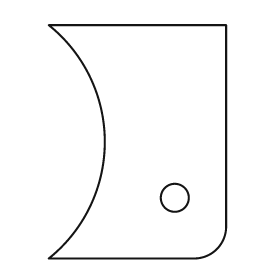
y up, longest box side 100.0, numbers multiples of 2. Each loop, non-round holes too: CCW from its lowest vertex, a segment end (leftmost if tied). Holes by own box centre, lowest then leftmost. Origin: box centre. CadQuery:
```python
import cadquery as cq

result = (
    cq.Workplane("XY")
    .moveTo(-38.0, -50.0)
    .lineTo(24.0, -50.0)
    .threePointArc((34.0, -46.0), (38.0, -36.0))
    .lineTo(38.0, 50.0)
    .lineTo(-38.0, 50.0)
    .threePointArc((-14.0, 0.0), (-38.0, -50.0))
    .close()
    .moveTo(16.0, -24.0)
    .circle(6.0)
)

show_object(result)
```